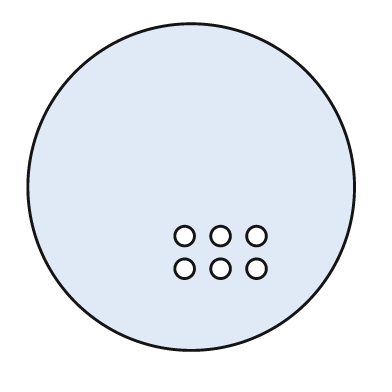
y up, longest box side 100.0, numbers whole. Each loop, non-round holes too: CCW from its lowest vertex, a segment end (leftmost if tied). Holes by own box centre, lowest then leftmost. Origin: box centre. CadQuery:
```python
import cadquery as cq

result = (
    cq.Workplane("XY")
    .moveTo(0.0, 0.0)
    .circle(50.0)
    .moveTo(-2.0, -25.0)
    .circle(3.0)
    .moveTo(9.0, -25.0)
    .circle(3.0)
    .moveTo(20.0, -25.0)
    .circle(3.0)
    .moveTo(-2.0, -15.0)
    .circle(3.0)
    .moveTo(9.0, -15.0)
    .circle(3.0)
    .moveTo(20.0, -15.0)
    .circle(3.0)
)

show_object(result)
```